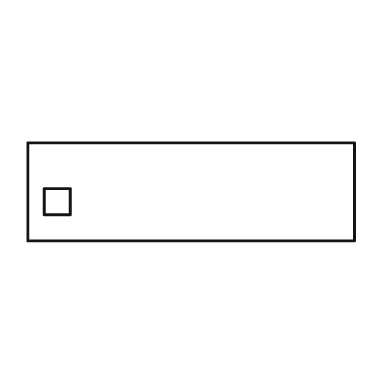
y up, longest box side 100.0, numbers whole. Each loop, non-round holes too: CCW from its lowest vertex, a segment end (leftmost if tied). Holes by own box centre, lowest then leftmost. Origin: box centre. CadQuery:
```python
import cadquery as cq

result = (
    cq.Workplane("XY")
    .moveTo(-50.0, -15.0)
    .lineTo(50.0, -15.0)
    .lineTo(50.0, 15.0)
    .lineTo(-50.0, 15.0)
    .close()
    .moveTo(-45.0, -7.0)
    .lineTo(-37.0, -7.0)
    .lineTo(-37.0, 1.0)
    .lineTo(-45.0, 1.0)
    .close()
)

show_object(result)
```